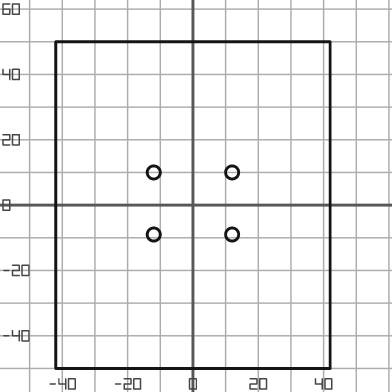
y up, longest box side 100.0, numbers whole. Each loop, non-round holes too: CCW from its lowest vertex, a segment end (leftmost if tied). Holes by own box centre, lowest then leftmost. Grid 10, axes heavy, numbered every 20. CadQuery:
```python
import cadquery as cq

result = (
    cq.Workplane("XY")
    .moveTo(-42.0, -50.0)
    .lineTo(42.0, -50.0)
    .lineTo(42.0, 50.0)
    .lineTo(-42.0, 50.0)
    .close()
    .moveTo(-12.0, -9.0)
    .circle(2.0)
    .moveTo(12.0, -9.0)
    .circle(2.0)
    .moveTo(-12.0, 10.0)
    .circle(2.0)
    .moveTo(12.0, 10.0)
    .circle(2.0)
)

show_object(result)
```